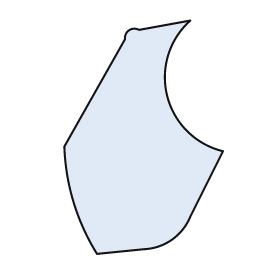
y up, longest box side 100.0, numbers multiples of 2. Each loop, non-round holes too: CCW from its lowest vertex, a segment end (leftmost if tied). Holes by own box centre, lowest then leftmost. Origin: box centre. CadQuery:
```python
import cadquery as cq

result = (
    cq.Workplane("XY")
    .moveTo(-20.0, -50.0)
    .lineTo(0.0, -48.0)
    .threePointArc((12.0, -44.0), (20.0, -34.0))
    .lineTo(34.0, -6.0)
    .threePointArc((10.0, 18.0), (20.0, 50.0))
    .lineTo(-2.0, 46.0)
    .threePointArc((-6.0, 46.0), (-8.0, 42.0))
    .lineTo(-34.0, -4.0)
    .threePointArc((-30.0, -28.0), (-20.0, -50.0))
    .close()
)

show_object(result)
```